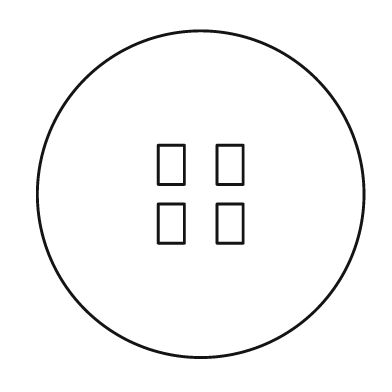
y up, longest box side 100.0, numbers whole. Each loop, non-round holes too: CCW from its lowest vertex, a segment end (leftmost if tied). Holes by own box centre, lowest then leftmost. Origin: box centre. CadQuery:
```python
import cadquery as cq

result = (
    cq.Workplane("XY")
    .moveTo(0.0, 0.0)
    .circle(50.0)
    .moveTo(-13.0, -15.0)
    .lineTo(-5.0, -15.0)
    .lineTo(-5.0, -3.0)
    .lineTo(-13.0, -3.0)
    .close()
    .moveTo(5.0, -15.0)
    .lineTo(13.0, -15.0)
    .lineTo(13.0, -3.0)
    .lineTo(5.0, -3.0)
    .close()
    .moveTo(-13.0, 3.0)
    .lineTo(-5.0, 3.0)
    .lineTo(-5.0, 15.0)
    .lineTo(-13.0, 15.0)
    .close()
    .moveTo(5.0, 3.0)
    .lineTo(13.0, 3.0)
    .lineTo(13.0, 15.0)
    .lineTo(5.0, 15.0)
    .close()
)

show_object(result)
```